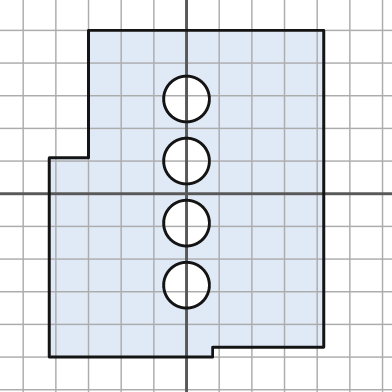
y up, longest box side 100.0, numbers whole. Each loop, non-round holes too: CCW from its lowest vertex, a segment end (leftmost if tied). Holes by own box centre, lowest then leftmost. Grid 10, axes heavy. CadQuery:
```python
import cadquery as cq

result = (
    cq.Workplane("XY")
    .moveTo(-42.0, -50.0)
    .lineTo(8.0, -50.0)
    .lineTo(8.0, -47.0)
    .lineTo(42.0, -47.0)
    .lineTo(42.0, 50.0)
    .lineTo(-30.0, 50.0)
    .lineTo(-30.0, 11.0)
    .lineTo(-42.0, 11.0)
    .close()
    .moveTo(0.0, -28.0)
    .circle(7.0)
    .moveTo(0.0, -9.0)
    .circle(7.0)
    .moveTo(0.0, 10.0)
    .circle(7.0)
    .moveTo(0.0, 29.0)
    .circle(7.0)
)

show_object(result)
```